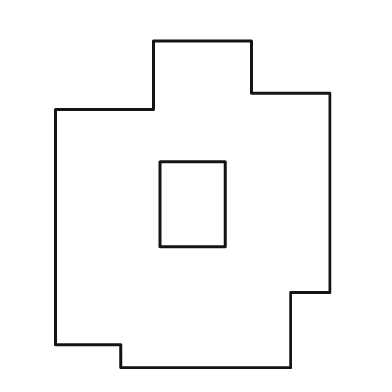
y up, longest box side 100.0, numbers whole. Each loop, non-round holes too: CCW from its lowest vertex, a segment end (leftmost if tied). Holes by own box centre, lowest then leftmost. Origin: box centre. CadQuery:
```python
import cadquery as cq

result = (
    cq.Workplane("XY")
    .moveTo(-22.0, -50.0)
    .lineTo(30.0, -50.0)
    .lineTo(30.0, -27.0)
    .lineTo(42.0, -27.0)
    .lineTo(42.0, 34.0)
    .lineTo(18.0, 34.0)
    .lineTo(18.0, 50.0)
    .lineTo(-12.0, 50.0)
    .lineTo(-12.0, 29.0)
    .lineTo(-42.0, 29.0)
    .lineTo(-42.0, -43.0)
    .lineTo(-22.0, -43.0)
    .close()
    .moveTo(-10.0, -13.0)
    .lineTo(10.0, -13.0)
    .lineTo(10.0, 13.0)
    .lineTo(-10.0, 13.0)
    .close()
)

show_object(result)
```